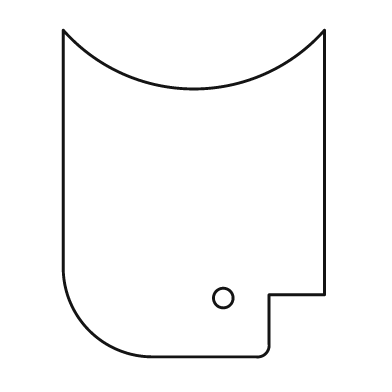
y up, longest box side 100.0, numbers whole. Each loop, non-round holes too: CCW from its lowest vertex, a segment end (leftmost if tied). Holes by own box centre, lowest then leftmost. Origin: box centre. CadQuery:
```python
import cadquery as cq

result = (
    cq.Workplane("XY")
    .moveTo(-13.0, -50.0)
    .lineTo(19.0, -50.0)
    .threePointArc((22.0, -49.0), (23.0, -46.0))
    .lineTo(23.0, -31.0)
    .lineTo(40.0, -31.0)
    .lineTo(40.0, 50.0)
    .threePointArc((0.0, 32.0), (-40.0, 50.0))
    .lineTo(-40.0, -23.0)
    .threePointArc((-32.0, -42.0), (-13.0, -50.0))
    .close()
    .moveTo(9.0, -32.0)
    .circle(3.0)
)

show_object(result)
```